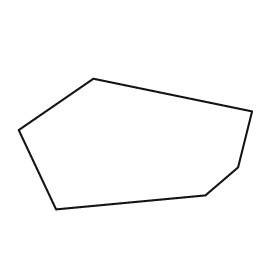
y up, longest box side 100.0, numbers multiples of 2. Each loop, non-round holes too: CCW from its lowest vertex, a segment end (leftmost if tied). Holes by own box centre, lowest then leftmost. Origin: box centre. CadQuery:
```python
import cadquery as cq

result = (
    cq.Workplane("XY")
    .moveTo(-34.0, -28.0)
    .lineTo(30.0, -22.0)
    .lineTo(44.0, -10.0)
    .lineTo(50.0, 14.0)
    .lineTo(-18.0, 28.0)
    .lineTo(-50.0, 6.0)
    .close()
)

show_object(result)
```